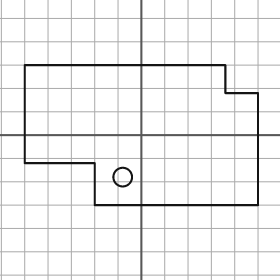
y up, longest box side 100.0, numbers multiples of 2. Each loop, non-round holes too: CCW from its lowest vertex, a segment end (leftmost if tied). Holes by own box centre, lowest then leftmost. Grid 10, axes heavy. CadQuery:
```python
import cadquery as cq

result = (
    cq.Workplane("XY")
    .moveTo(-20.0, -30.0)
    .lineTo(50.0, -30.0)
    .lineTo(50.0, 18.0)
    .lineTo(36.0, 18.0)
    .lineTo(36.0, 30.0)
    .lineTo(-50.0, 30.0)
    .lineTo(-50.0, -12.0)
    .lineTo(-20.0, -12.0)
    .close()
    .moveTo(-8.0, -18.0)
    .circle(4.0)
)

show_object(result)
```